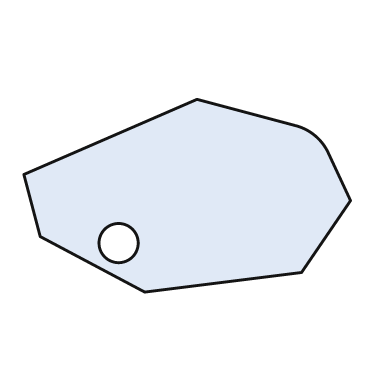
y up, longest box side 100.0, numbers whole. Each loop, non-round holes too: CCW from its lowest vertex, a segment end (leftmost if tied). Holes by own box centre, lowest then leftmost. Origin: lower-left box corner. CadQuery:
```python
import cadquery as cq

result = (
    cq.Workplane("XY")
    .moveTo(37.0, 0.0)
    .lineTo(85.0, 6.0)
    .lineTo(100.0, 28.0)
    .lineTo(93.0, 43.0)
    .threePointArc((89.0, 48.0), (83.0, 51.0))
    .lineTo(53.0, 59.0)
    .lineTo(0.0, 36.0)
    .lineTo(5.0, 17.0)
    .close()
    .moveTo(29.0, 15.0)
    .circle(6.0)
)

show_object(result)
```